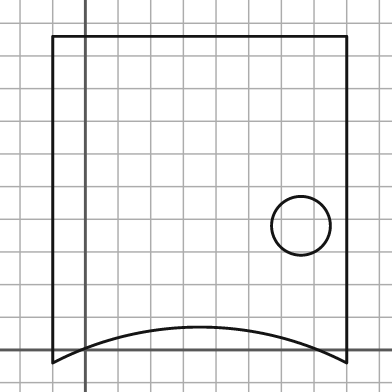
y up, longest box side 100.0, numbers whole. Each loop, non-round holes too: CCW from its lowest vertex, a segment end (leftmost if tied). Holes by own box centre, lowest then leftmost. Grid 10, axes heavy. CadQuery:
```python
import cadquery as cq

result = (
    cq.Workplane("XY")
    .moveTo(-10.0, -4.0)
    .threePointArc((35.0, 7.0), (80.0, -4.0))
    .lineTo(80.0, 96.0)
    .lineTo(-10.0, 96.0)
    .close()
    .moveTo(66.0, 38.0)
    .circle(9.0)
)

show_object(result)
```